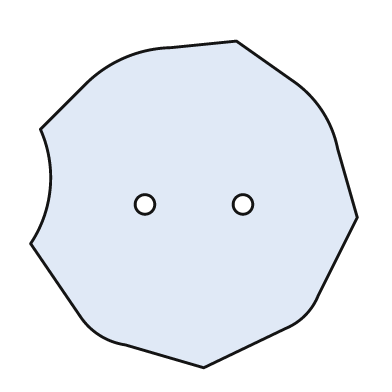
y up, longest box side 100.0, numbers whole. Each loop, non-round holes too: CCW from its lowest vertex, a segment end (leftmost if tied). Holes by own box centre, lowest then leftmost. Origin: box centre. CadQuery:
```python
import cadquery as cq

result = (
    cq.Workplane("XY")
    .moveTo(3.0, -50.0)
    .lineTo(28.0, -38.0)
    .threePointArc((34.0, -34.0), (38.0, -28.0))
    .lineTo(50.0, -4.0)
    .lineTo(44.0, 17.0)
    .threePointArc((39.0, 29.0), (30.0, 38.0))
    .lineTo(13.0, 50.0)
    .lineTo(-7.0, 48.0)
    .threePointArc((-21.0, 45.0), (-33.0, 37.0))
    .lineTo(-47.0, 23.0)
    .threePointArc((-44.0, 5.0), (-50.0, -12.0))
    .lineTo(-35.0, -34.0)
    .threePointArc((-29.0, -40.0), (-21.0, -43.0))
    .close()
    .moveTo(-15.0, 0.0)
    .circle(3.0)
    .moveTo(15.0, 0.0)
    .circle(3.0)
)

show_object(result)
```